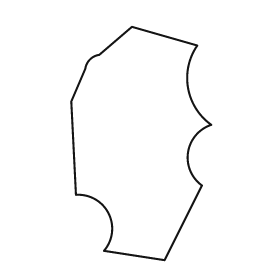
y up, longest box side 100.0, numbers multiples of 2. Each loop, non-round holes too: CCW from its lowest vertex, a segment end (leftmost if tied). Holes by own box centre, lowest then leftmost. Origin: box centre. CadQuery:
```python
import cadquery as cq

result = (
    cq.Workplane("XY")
    .moveTo(10.0, -50.0)
    .lineTo(26.0, -18.0)
    .threePointArc((20.0, -4.0), (30.0, 8.0))
    .threePointArc((20.0, 24.0), (24.0, 42.0))
    .lineTo(-4.0, 50.0)
    .lineTo(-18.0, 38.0)
    .threePointArc((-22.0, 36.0), (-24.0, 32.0))
    .lineTo(-30.0, 18.0)
    .lineTo(-28.0, -22.0)
    .threePointArc((-14.0, -30.0), (-16.0, -46.0))
    .close()
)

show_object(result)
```